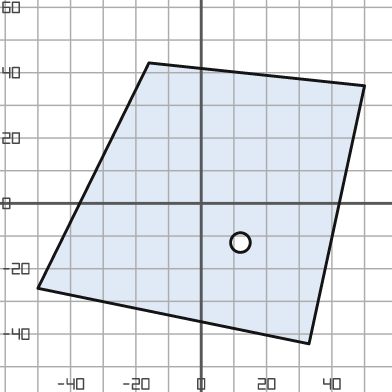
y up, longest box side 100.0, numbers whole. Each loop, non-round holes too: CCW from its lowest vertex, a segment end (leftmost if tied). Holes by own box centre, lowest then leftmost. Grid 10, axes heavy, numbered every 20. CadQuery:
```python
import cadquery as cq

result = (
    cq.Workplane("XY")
    .moveTo(33.0, -43.0)
    .lineTo(50.0, 36.0)
    .lineTo(-16.0, 43.0)
    .lineTo(-50.0, -26.0)
    .close()
    .moveTo(12.0, -12.0)
    .circle(3.0)
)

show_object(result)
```